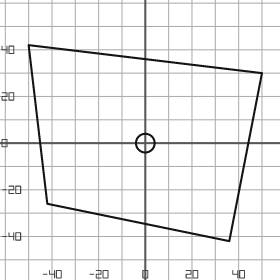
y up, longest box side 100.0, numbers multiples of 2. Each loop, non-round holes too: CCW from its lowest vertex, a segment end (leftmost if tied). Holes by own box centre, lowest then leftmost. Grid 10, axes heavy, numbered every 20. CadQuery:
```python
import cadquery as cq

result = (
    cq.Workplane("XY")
    .moveTo(36.0, -42.0)
    .lineTo(50.0, 30.0)
    .lineTo(-50.0, 42.0)
    .lineTo(-42.0, -26.0)
    .close()
    .moveTo(0.0, 0.0)
    .circle(4.0)
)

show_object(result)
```